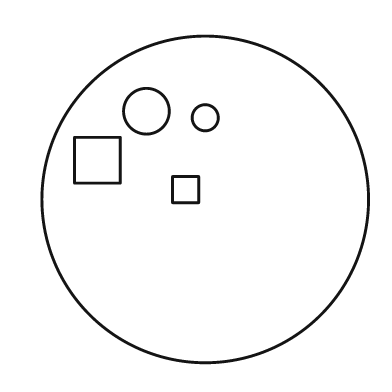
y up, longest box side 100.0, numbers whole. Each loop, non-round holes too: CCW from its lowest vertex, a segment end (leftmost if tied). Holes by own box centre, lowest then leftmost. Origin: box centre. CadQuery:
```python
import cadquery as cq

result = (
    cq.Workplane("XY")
    .moveTo(0.0, 0.0)
    .circle(50.0)
    .moveTo(-10.0, -1.0)
    .lineTo(-2.0, -1.0)
    .lineTo(-2.0, 7.0)
    .lineTo(-10.0, 7.0)
    .close()
    .moveTo(-40.0, 5.0)
    .lineTo(-26.0, 5.0)
    .lineTo(-26.0, 19.0)
    .lineTo(-40.0, 19.0)
    .close()
    .moveTo(0.0, 25.0)
    .circle(4.0)
    .moveTo(-18.0, 27.0)
    .circle(7.0)
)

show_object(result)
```